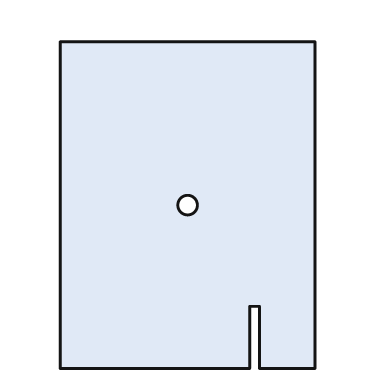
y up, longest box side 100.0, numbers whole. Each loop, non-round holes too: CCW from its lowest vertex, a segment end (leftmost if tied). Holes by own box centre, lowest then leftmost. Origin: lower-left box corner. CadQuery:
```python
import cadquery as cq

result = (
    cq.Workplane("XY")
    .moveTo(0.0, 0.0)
    .lineTo(58.0, 0.0)
    .lineTo(58.0, 19.0)
    .lineTo(61.0, 19.0)
    .lineTo(61.0, 0.0)
    .lineTo(78.0, 0.0)
    .lineTo(78.0, 100.0)
    .lineTo(0.0, 100.0)
    .close()
    .moveTo(39.0, 50.0)
    .circle(3.0)
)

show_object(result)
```